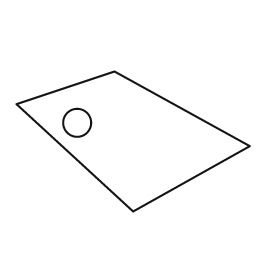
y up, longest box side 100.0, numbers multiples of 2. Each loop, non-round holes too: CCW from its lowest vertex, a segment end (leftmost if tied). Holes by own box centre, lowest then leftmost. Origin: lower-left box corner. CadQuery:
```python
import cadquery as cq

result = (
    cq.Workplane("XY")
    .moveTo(50.0, 0.0)
    .lineTo(100.0, 28.0)
    .lineTo(42.0, 60.0)
    .lineTo(0.0, 46.0)
    .close()
    .moveTo(26.0, 38.0)
    .circle(6.0)
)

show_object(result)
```